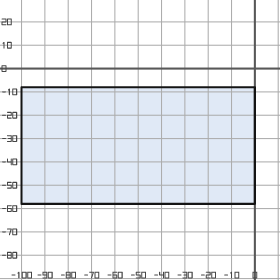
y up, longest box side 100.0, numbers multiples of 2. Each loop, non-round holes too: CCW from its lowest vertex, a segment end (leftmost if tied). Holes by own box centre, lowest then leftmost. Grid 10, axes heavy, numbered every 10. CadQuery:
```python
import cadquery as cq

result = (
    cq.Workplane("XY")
    .moveTo(-100.0, -58.0)
    .lineTo(0.0, -58.0)
    .lineTo(0.0, -8.0)
    .lineTo(-100.0, -8.0)
    .close()
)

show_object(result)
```